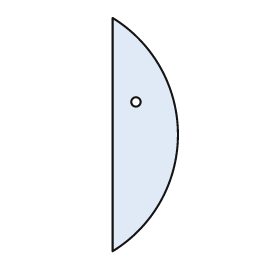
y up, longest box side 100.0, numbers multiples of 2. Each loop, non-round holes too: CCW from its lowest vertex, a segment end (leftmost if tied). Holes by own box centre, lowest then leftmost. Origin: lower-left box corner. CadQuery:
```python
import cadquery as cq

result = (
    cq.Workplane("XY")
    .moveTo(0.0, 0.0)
    .threePointArc((28.0, 50.0), (0.0, 100.0))
    .close()
    .moveTo(10.0, 64.0)
    .circle(2.0)
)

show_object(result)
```